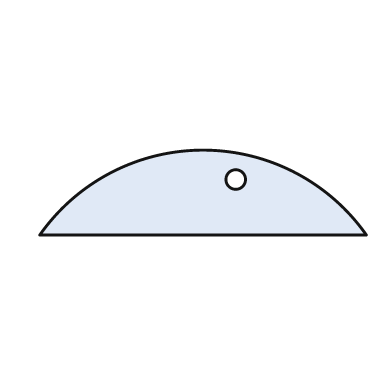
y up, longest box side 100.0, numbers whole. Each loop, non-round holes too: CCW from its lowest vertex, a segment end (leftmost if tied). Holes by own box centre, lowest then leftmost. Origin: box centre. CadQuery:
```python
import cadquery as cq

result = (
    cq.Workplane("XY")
    .moveTo(-50.0, -13.0)
    .lineTo(50.0, -13.0)
    .threePointArc((0.0, 13.0), (-50.0, -13.0))
    .close()
    .moveTo(10.0, 4.0)
    .circle(3.0)
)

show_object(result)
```